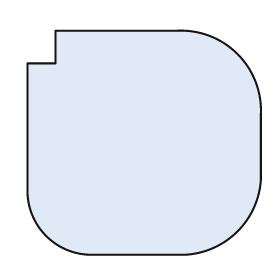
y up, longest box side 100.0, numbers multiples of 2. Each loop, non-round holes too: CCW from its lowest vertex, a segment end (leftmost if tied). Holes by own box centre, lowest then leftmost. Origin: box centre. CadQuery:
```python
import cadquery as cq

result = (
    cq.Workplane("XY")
    .moveTo(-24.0, -48.0)
    .lineTo(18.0, -48.0)
    .threePointArc((40.0, -38.0), (50.0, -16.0))
    .lineTo(50.0, 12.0)
    .threePointArc((40.0, 38.0), (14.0, 48.0))
    .lineTo(-38.0, 48.0)
    .lineTo(-38.0, 34.0)
    .lineTo(-50.0, 34.0)
    .lineTo(-50.0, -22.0)
    .threePointArc((-42.0, -40.0), (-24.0, -48.0))
    .close()
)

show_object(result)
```